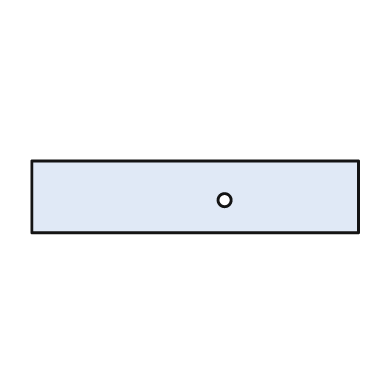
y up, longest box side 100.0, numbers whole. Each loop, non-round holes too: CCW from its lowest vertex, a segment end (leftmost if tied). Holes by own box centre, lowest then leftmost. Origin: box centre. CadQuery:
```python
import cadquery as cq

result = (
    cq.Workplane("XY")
    .moveTo(-50.0, -11.0)
    .lineTo(50.0, -11.0)
    .lineTo(50.0, 11.0)
    .lineTo(-50.0, 11.0)
    .close()
    .moveTo(9.0, -1.0)
    .circle(2.0)
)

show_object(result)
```